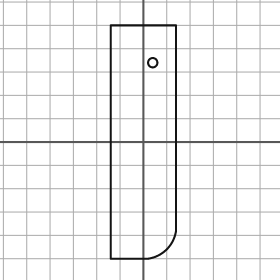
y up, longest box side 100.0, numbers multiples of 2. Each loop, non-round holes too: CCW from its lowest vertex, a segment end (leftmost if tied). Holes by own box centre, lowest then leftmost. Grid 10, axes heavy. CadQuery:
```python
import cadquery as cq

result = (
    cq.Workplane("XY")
    .moveTo(-14.0, -50.0)
    .lineTo(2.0, -50.0)
    .threePointArc((10.0, -46.0), (14.0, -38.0))
    .lineTo(14.0, 50.0)
    .lineTo(-14.0, 50.0)
    .close()
    .moveTo(4.0, 34.0)
    .circle(2.0)
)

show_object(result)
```